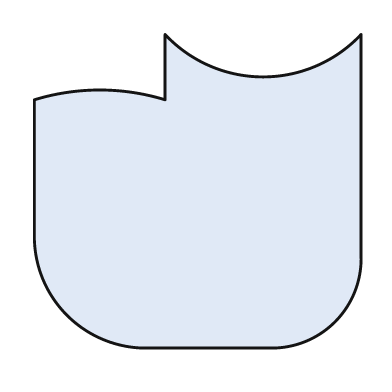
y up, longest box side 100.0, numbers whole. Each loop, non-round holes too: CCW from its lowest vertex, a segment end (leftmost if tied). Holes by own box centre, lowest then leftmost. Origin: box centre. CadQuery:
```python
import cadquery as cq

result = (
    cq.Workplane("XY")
    .moveTo(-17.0, -48.0)
    .lineTo(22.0, -48.0)
    .threePointArc((42.0, -40.0), (50.0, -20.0))
    .lineTo(50.0, 48.0)
    .threePointArc((20.0, 35.0), (-10.0, 48.0))
    .lineTo(-10.0, 28.0)
    .threePointArc((-30.0, 31.0), (-50.0, 28.0))
    .lineTo(-50.0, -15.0)
    .threePointArc((-40.0, -38.0), (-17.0, -48.0))
    .close()
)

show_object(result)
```